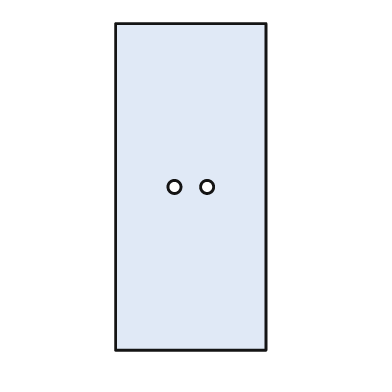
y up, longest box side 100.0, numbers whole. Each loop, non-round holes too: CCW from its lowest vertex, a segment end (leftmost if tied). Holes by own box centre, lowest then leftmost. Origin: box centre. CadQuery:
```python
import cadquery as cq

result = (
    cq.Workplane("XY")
    .moveTo(-23.0, -50.0)
    .lineTo(23.0, -50.0)
    .lineTo(23.0, 50.0)
    .lineTo(-23.0, 50.0)
    .close()
    .moveTo(-5.0, 0.0)
    .circle(2.0)
    .moveTo(5.0, 0.0)
    .circle(2.0)
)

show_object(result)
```